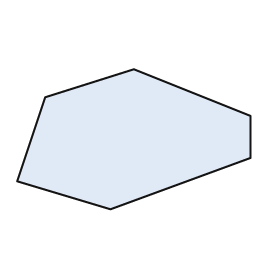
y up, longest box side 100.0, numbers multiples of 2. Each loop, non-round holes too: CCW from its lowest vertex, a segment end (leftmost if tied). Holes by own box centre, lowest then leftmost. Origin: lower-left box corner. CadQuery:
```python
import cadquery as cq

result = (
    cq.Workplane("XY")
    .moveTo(40.0, 0.0)
    .lineTo(100.0, 22.0)
    .lineTo(100.0, 40.0)
    .lineTo(50.0, 60.0)
    .lineTo(12.0, 48.0)
    .lineTo(0.0, 12.0)
    .close()
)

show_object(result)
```